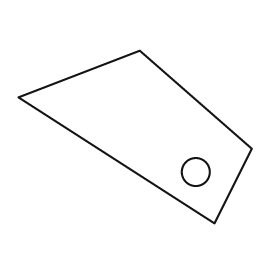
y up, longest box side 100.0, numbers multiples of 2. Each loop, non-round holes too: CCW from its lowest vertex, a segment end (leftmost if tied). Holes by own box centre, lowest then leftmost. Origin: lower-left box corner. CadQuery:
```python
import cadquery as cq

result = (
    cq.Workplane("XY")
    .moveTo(84.0, 0.0)
    .lineTo(100.0, 32.0)
    .lineTo(52.0, 74.0)
    .lineTo(0.0, 54.0)
    .close()
    .moveTo(76.0, 22.0)
    .circle(6.0)
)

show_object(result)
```